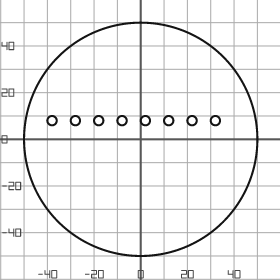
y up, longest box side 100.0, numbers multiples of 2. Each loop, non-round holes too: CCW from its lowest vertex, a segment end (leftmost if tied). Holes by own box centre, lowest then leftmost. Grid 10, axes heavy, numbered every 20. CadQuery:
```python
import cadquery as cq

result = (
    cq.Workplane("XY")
    .moveTo(0.0, 0.0)
    .circle(50.0)
    .moveTo(-38.0, 8.0)
    .circle(2.0)
    .moveTo(-28.0, 8.0)
    .circle(2.0)
    .moveTo(-18.0, 8.0)
    .circle(2.0)
    .moveTo(-8.0, 8.0)
    .circle(2.0)
    .moveTo(2.0, 8.0)
    .circle(2.0)
    .moveTo(12.0, 8.0)
    .circle(2.0)
    .moveTo(22.0, 8.0)
    .circle(2.0)
    .moveTo(32.0, 8.0)
    .circle(2.0)
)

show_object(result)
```